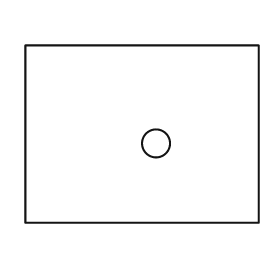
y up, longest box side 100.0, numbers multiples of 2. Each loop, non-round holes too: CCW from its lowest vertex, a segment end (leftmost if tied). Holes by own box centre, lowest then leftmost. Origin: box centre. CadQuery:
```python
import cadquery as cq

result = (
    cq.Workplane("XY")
    .moveTo(-50.0, -38.0)
    .lineTo(50.0, -38.0)
    .lineTo(50.0, 38.0)
    .lineTo(-50.0, 38.0)
    .close()
    .moveTo(6.0, -4.0)
    .circle(6.0)
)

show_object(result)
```